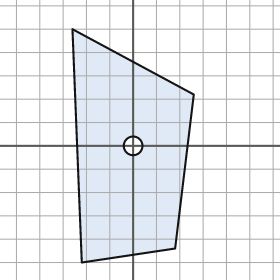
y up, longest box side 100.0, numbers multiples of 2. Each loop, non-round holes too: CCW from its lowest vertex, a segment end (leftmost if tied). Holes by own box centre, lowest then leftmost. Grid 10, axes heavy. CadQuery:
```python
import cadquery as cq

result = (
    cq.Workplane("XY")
    .moveTo(-22.0, -50.0)
    .lineTo(18.0, -44.0)
    .lineTo(26.0, 22.0)
    .lineTo(-26.0, 50.0)
    .close()
    .moveTo(0.0, 0.0)
    .circle(4.0)
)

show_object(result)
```